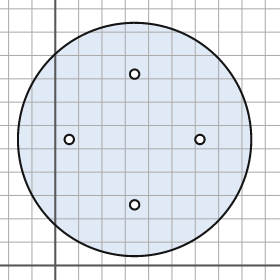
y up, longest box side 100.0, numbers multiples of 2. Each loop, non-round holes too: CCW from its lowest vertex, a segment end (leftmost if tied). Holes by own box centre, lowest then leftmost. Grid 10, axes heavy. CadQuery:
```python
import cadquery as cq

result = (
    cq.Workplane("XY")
    .moveTo(34.0, 54.0)
    .circle(50.0)
    .moveTo(34.0, 26.0)
    .circle(2.0)
    .moveTo(6.0, 54.0)
    .circle(2.0)
    .moveTo(62.0, 54.0)
    .circle(2.0)
    .moveTo(34.0, 82.0)
    .circle(2.0)
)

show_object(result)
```